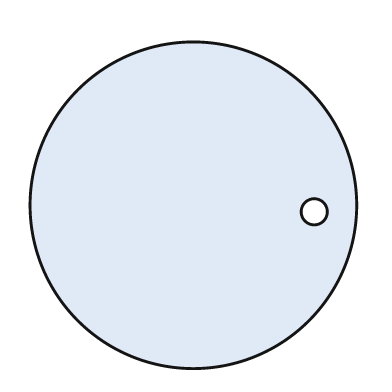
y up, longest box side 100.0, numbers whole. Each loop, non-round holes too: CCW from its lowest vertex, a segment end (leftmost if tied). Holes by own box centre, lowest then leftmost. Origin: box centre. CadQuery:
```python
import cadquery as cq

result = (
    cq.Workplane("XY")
    .moveTo(0.0, 0.0)
    .circle(50.0)
    .moveTo(37.0, -2.0)
    .circle(4.0)
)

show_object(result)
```